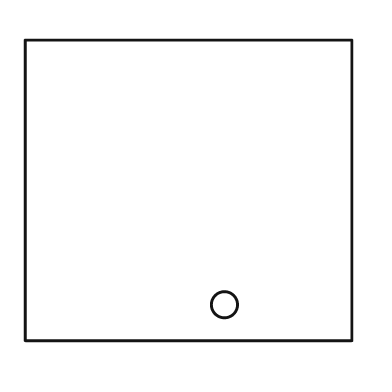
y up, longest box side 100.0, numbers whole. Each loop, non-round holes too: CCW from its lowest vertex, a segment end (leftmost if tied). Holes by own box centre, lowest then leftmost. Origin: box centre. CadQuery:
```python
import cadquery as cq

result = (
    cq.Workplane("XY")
    .moveTo(-50.0, -46.0)
    .lineTo(50.0, -46.0)
    .lineTo(50.0, 46.0)
    .lineTo(-50.0, 46.0)
    .close()
    .moveTo(11.0, -35.0)
    .circle(4.0)
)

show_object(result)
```